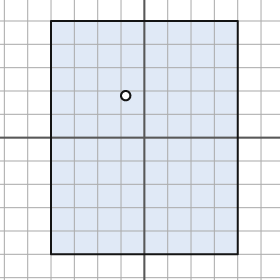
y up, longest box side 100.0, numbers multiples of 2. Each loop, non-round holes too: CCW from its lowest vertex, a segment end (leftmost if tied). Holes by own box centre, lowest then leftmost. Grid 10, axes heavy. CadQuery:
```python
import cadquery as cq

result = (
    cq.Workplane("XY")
    .moveTo(-40.0, -50.0)
    .lineTo(40.0, -50.0)
    .lineTo(40.0, 50.0)
    .lineTo(-40.0, 50.0)
    .close()
    .moveTo(-8.0, 18.0)
    .circle(2.0)
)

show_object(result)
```